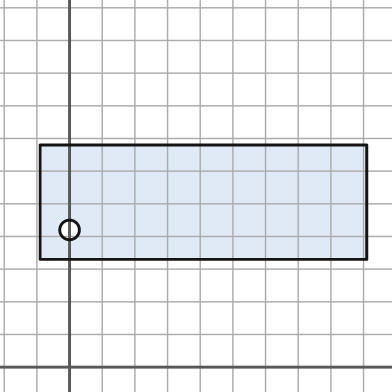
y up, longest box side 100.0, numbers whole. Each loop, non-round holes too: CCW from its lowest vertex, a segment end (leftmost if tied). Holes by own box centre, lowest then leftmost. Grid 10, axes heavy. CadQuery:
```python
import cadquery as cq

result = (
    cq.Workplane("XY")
    .moveTo(-9.0, 33.0)
    .lineTo(91.0, 33.0)
    .lineTo(91.0, 68.0)
    .lineTo(-9.0, 68.0)
    .close()
    .moveTo(0.0, 42.0)
    .circle(3.0)
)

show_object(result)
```